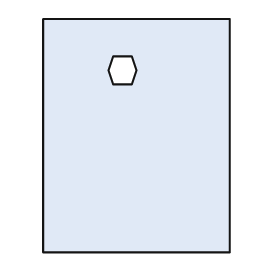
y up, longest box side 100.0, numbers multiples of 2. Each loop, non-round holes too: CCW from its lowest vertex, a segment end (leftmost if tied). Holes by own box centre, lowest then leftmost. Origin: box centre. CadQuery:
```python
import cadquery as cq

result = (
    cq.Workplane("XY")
    .moveTo(-40.0, -50.0)
    .lineTo(40.0, -50.0)
    .lineTo(40.0, 50.0)
    .lineTo(-40.0, 50.0)
    .close()
    .moveTo(-10.0, 22.0)
    .lineTo(-2.0, 22.0)
    .lineTo(0.0, 28.0)
    .lineTo(-2.0, 34.0)
    .lineTo(-10.0, 34.0)
    .lineTo(-12.0, 28.0)
    .close()
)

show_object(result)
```